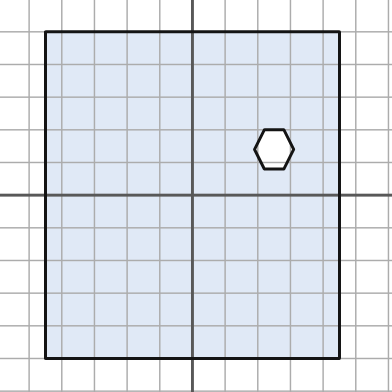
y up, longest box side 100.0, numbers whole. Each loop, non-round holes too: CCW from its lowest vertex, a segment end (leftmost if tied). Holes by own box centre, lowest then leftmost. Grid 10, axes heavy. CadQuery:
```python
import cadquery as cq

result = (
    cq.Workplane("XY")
    .moveTo(-45.0, -50.0)
    .lineTo(45.0, -50.0)
    .lineTo(45.0, 50.0)
    .lineTo(-45.0, 50.0)
    .close()
    .moveTo(22.0, 8.0)
    .lineTo(28.0, 8.0)
    .lineTo(31.0, 14.0)
    .lineTo(28.0, 20.0)
    .lineTo(22.0, 20.0)
    .lineTo(19.0, 14.0)
    .close()
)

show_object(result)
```